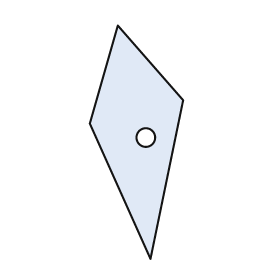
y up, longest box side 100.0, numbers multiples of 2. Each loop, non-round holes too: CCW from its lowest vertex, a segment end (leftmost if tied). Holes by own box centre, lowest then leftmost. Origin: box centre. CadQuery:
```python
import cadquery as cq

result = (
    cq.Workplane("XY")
    .moveTo(6.0, -50.0)
    .lineTo(20.0, 18.0)
    .lineTo(-8.0, 50.0)
    .lineTo(-20.0, 8.0)
    .close()
    .moveTo(4.0, 2.0)
    .circle(4.0)
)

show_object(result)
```